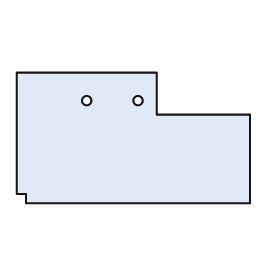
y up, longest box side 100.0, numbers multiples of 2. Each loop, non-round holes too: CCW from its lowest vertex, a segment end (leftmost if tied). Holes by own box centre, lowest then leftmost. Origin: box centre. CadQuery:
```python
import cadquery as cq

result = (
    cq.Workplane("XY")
    .moveTo(-46.0, -28.0)
    .lineTo(50.0, -28.0)
    .lineTo(50.0, 10.0)
    .lineTo(10.0, 10.0)
    .lineTo(10.0, 28.0)
    .lineTo(-50.0, 28.0)
    .lineTo(-50.0, -24.0)
    .lineTo(-46.0, -24.0)
    .close()
    .moveTo(-20.0, 16.0)
    .circle(2.0)
    .moveTo(2.0, 16.0)
    .circle(2.0)
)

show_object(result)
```